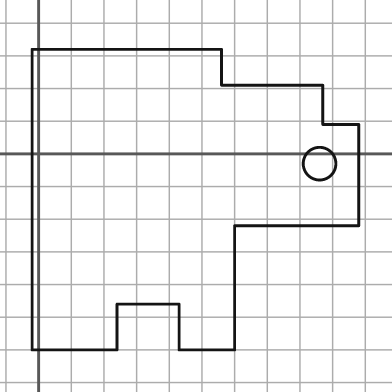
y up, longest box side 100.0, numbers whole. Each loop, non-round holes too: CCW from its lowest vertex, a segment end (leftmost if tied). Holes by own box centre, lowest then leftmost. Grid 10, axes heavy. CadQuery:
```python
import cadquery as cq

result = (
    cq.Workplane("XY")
    .moveTo(-2.0, -60.0)
    .lineTo(24.0, -60.0)
    .lineTo(24.0, -46.0)
    .lineTo(43.0, -46.0)
    .lineTo(43.0, -60.0)
    .lineTo(60.0, -60.0)
    .lineTo(60.0, -22.0)
    .lineTo(98.0, -22.0)
    .lineTo(98.0, 9.0)
    .lineTo(87.0, 9.0)
    .lineTo(87.0, 21.0)
    .lineTo(56.0, 21.0)
    .lineTo(56.0, 32.0)
    .lineTo(-2.0, 32.0)
    .close()
    .moveTo(86.0, -3.0)
    .circle(5.0)
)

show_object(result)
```